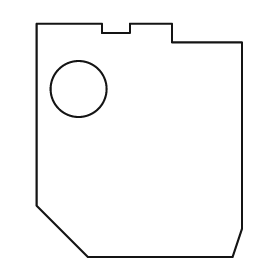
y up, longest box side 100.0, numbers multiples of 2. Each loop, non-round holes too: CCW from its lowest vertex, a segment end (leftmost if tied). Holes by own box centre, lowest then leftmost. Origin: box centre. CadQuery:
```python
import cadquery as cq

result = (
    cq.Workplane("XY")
    .moveTo(-22.0, -50.0)
    .lineTo(40.0, -50.0)
    .lineTo(44.0, -38.0)
    .lineTo(44.0, 42.0)
    .lineTo(14.0, 42.0)
    .lineTo(14.0, 50.0)
    .lineTo(-4.0, 50.0)
    .lineTo(-4.0, 46.0)
    .lineTo(-16.0, 46.0)
    .lineTo(-16.0, 50.0)
    .lineTo(-44.0, 50.0)
    .lineTo(-44.0, -28.0)
    .close()
    .moveTo(-26.0, 22.0)
    .circle(12.0)
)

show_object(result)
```